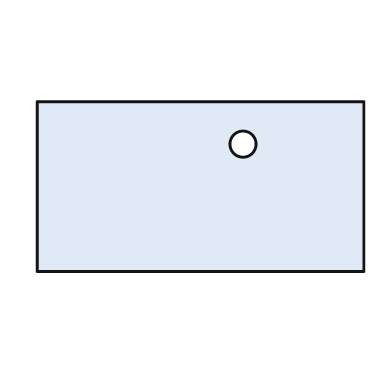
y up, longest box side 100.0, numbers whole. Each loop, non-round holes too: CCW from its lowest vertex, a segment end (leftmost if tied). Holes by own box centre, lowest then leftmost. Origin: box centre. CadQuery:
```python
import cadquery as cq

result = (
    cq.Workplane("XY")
    .moveTo(-50.0, -26.0)
    .lineTo(50.0, -26.0)
    .lineTo(50.0, 26.0)
    .lineTo(-50.0, 26.0)
    .close()
    .moveTo(13.0, 13.0)
    .circle(4.0)
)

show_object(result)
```